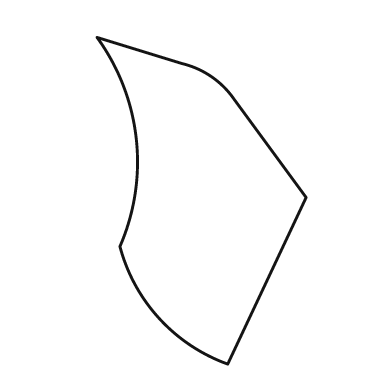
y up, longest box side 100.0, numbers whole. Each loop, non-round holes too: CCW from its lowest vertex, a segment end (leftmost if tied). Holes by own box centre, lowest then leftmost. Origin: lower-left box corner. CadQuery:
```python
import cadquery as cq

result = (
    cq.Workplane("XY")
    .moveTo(40.0, 0.0)
    .lineTo(64.0, 51.0)
    .lineTo(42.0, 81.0)
    .threePointArc((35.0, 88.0), (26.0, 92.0))
    .lineTo(0.0, 100.0)
    .threePointArc((12.0, 69.0), (7.0, 36.0))
    .threePointArc((19.0, 14.0), (40.0, 0.0))
    .close()
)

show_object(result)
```